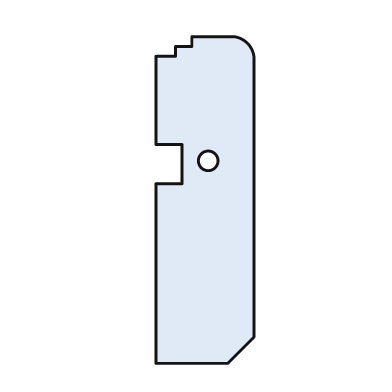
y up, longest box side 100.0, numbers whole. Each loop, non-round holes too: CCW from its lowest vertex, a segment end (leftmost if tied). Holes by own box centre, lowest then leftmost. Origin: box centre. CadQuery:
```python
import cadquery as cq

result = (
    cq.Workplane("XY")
    .moveTo(-15.0, -50.0)
    .lineTo(7.0, -50.0)
    .lineTo(15.0, -42.0)
    .lineTo(15.0, 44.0)
    .threePointArc((13.0, 48.0), (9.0, 50.0))
    .lineTo(-4.0, 50.0)
    .lineTo(-4.0, 47.0)
    .lineTo(-9.0, 47.0)
    .lineTo(-9.0, 44.0)
    .lineTo(-15.0, 44.0)
    .lineTo(-15.0, 17.0)
    .lineTo(-7.0, 17.0)
    .lineTo(-7.0, 5.0)
    .lineTo(-15.0, 5.0)
    .close()
    .moveTo(1.0, 12.0)
    .circle(3.0)
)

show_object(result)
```